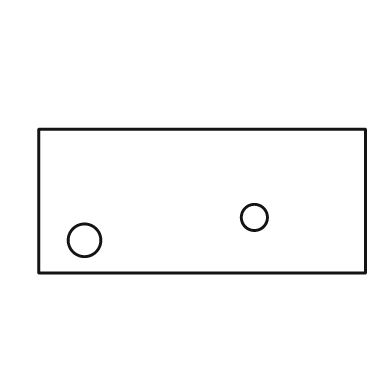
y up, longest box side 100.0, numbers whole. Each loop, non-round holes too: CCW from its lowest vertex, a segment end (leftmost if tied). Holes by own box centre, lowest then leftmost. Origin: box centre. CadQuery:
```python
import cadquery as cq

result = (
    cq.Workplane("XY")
    .moveTo(-50.0, -22.0)
    .lineTo(50.0, -22.0)
    .lineTo(50.0, 22.0)
    .lineTo(-50.0, 22.0)
    .close()
    .moveTo(-36.0, -12.0)
    .circle(5.0)
    .moveTo(16.0, -5.0)
    .circle(4.0)
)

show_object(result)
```